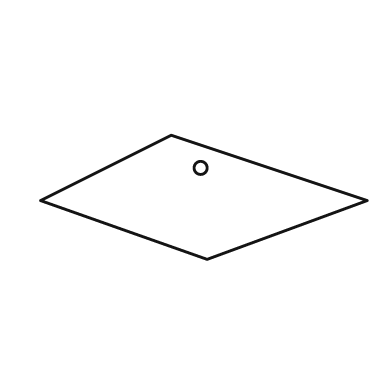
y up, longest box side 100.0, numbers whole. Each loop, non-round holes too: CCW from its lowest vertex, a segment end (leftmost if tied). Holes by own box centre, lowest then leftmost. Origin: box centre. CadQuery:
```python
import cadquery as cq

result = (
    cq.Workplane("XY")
    .moveTo(1.0, -19.0)
    .lineTo(50.0, -1.0)
    .lineTo(-10.0, 19.0)
    .lineTo(-50.0, -1.0)
    .close()
    .moveTo(-1.0, 9.0)
    .circle(2.0)
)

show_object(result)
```